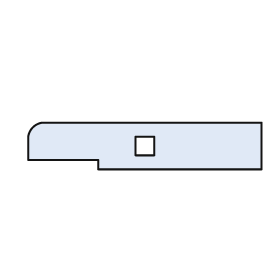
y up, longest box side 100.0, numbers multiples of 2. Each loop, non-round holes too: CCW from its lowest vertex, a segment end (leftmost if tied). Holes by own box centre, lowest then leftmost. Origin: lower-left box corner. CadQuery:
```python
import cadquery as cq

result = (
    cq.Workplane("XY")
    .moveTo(30.0, 0.0)
    .lineTo(100.0, 0.0)
    .lineTo(100.0, 20.0)
    .lineTo(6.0, 20.0)
    .threePointArc((2.0, 18.0), (0.0, 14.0))
    .lineTo(0.0, 4.0)
    .lineTo(30.0, 4.0)
    .close()
    .moveTo(46.0, 6.0)
    .lineTo(54.0, 6.0)
    .lineTo(54.0, 14.0)
    .lineTo(46.0, 14.0)
    .close()
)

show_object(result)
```